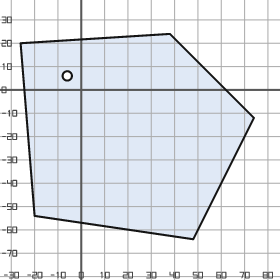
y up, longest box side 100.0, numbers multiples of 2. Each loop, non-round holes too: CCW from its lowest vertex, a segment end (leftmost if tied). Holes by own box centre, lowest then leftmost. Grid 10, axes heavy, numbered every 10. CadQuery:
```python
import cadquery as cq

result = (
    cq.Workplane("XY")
    .moveTo(48.0, -64.0)
    .lineTo(74.0, -12.0)
    .lineTo(38.0, 24.0)
    .lineTo(-26.0, 20.0)
    .lineTo(-20.0, -54.0)
    .close()
    .moveTo(-6.0, 6.0)
    .circle(2.0)
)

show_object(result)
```